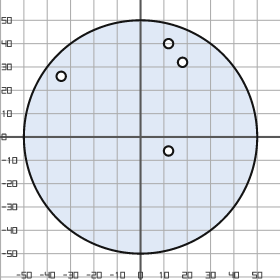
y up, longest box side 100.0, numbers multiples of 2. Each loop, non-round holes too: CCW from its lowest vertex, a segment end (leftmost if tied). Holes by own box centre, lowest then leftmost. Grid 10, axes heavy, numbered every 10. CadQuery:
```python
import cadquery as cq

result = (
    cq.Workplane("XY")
    .moveTo(0.0, 0.0)
    .circle(50.0)
    .moveTo(12.0, -6.0)
    .circle(2.0)
    .moveTo(-34.0, 26.0)
    .circle(2.0)
    .moveTo(18.0, 32.0)
    .circle(2.0)
    .moveTo(12.0, 40.0)
    .circle(2.0)
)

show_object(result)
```